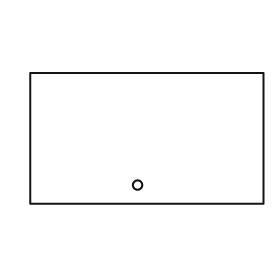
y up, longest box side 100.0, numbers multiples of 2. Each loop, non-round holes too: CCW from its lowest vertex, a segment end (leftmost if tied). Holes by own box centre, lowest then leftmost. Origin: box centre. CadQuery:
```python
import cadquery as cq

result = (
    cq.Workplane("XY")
    .moveTo(-50.0, -28.0)
    .lineTo(50.0, -28.0)
    .lineTo(50.0, 28.0)
    .lineTo(-50.0, 28.0)
    .close()
    .moveTo(-4.0, -20.0)
    .circle(2.0)
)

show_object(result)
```